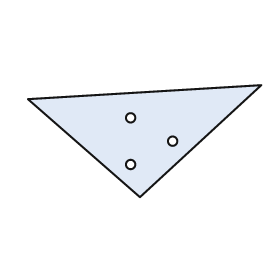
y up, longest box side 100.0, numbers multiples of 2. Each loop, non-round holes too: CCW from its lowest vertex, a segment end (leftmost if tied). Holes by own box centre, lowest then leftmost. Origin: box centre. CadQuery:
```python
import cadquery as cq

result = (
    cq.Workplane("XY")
    .moveTo(-2.0, -24.0)
    .lineTo(50.0, 24.0)
    .lineTo(-50.0, 18.0)
    .close()
    .moveTo(-6.0, -10.0)
    .circle(2.0)
    .moveTo(12.0, 0.0)
    .circle(2.0)
    .moveTo(-6.0, 10.0)
    .circle(2.0)
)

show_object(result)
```